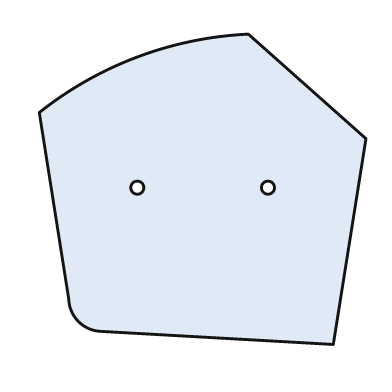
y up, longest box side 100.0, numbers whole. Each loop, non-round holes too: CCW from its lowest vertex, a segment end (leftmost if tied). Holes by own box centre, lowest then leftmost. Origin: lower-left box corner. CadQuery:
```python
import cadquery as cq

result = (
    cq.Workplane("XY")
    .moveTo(90.0, 0.0)
    .lineTo(100.0, 63.0)
    .lineTo(64.0, 95.0)
    .threePointArc((30.0, 88.0), (0.0, 71.0))
    .lineTo(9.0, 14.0)
    .threePointArc((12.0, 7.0), (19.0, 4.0))
    .close()
    .moveTo(30.0, 48.0)
    .circle(2.0)
    .moveTo(70.0, 48.0)
    .circle(2.0)
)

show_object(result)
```